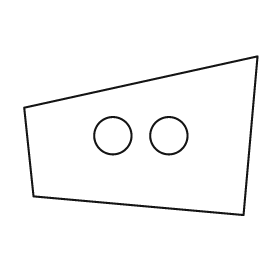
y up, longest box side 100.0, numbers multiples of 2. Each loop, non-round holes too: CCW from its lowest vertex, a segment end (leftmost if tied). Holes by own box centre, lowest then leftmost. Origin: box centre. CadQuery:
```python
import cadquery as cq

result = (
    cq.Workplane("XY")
    .moveTo(44.0, -34.0)
    .lineTo(50.0, 34.0)
    .lineTo(-50.0, 12.0)
    .lineTo(-46.0, -26.0)
    .close()
    .moveTo(-12.0, 0.0)
    .circle(8.0)
    .moveTo(12.0, 0.0)
    .circle(8.0)
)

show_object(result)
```